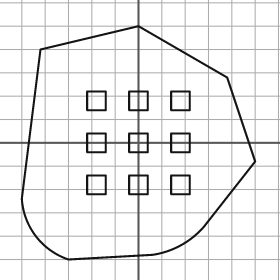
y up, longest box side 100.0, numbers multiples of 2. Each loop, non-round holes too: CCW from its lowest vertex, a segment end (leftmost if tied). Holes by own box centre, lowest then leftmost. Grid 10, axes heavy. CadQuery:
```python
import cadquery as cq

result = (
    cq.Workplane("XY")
    .moveTo(-30.0, -50.0)
    .lineTo(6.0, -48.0)
    .threePointArc((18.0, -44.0), (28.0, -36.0))
    .lineTo(50.0, -8.0)
    .lineTo(38.0, 28.0)
    .lineTo(0.0, 50.0)
    .lineTo(-42.0, 40.0)
    .lineTo(-50.0, -24.0)
    .threePointArc((-44.0, -40.0), (-30.0, -50.0))
    .close()
    .moveTo(-22.0, -22.0)
    .lineTo(-14.0, -22.0)
    .lineTo(-14.0, -14.0)
    .lineTo(-22.0, -14.0)
    .close()
    .moveTo(-4.0, -22.0)
    .lineTo(4.0, -22.0)
    .lineTo(4.0, -14.0)
    .lineTo(-4.0, -14.0)
    .close()
    .moveTo(14.0, -22.0)
    .lineTo(22.0, -22.0)
    .lineTo(22.0, -14.0)
    .lineTo(14.0, -14.0)
    .close()
    .moveTo(-22.0, -4.0)
    .lineTo(-14.0, -4.0)
    .lineTo(-14.0, 4.0)
    .lineTo(-22.0, 4.0)
    .close()
    .moveTo(-4.0, -4.0)
    .lineTo(4.0, -4.0)
    .lineTo(4.0, 4.0)
    .lineTo(-4.0, 4.0)
    .close()
    .moveTo(14.0, -4.0)
    .lineTo(22.0, -4.0)
    .lineTo(22.0, 4.0)
    .lineTo(14.0, 4.0)
    .close()
    .moveTo(-22.0, 14.0)
    .lineTo(-14.0, 14.0)
    .lineTo(-14.0, 22.0)
    .lineTo(-22.0, 22.0)
    .close()
    .moveTo(-4.0, 14.0)
    .lineTo(4.0, 14.0)
    .lineTo(4.0, 22.0)
    .lineTo(-4.0, 22.0)
    .close()
    .moveTo(14.0, 14.0)
    .lineTo(22.0, 14.0)
    .lineTo(22.0, 22.0)
    .lineTo(14.0, 22.0)
    .close()
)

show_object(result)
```